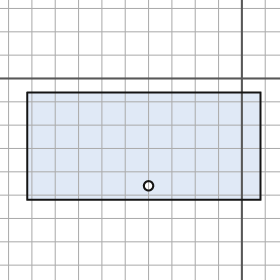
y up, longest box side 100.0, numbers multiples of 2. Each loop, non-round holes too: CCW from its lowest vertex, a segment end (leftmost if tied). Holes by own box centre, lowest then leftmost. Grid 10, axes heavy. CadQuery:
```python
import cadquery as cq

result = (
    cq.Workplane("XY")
    .moveTo(-92.0, -52.0)
    .lineTo(8.0, -52.0)
    .lineTo(8.0, -6.0)
    .lineTo(-92.0, -6.0)
    .close()
    .moveTo(-40.0, -46.0)
    .circle(2.0)
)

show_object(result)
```